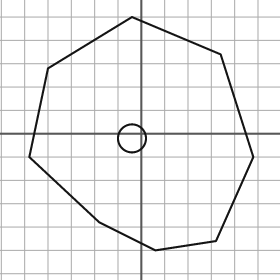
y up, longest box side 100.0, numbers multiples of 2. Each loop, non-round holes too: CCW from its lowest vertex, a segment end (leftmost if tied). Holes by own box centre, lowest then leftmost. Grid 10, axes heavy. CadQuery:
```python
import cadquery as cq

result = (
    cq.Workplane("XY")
    .moveTo(6.0, -50.0)
    .lineTo(32.0, -46.0)
    .lineTo(48.0, -10.0)
    .lineTo(34.0, 34.0)
    .lineTo(-4.0, 50.0)
    .lineTo(-40.0, 28.0)
    .lineTo(-48.0, -10.0)
    .lineTo(-18.0, -38.0)
    .close()
    .moveTo(-4.0, -2.0)
    .circle(6.0)
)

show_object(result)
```